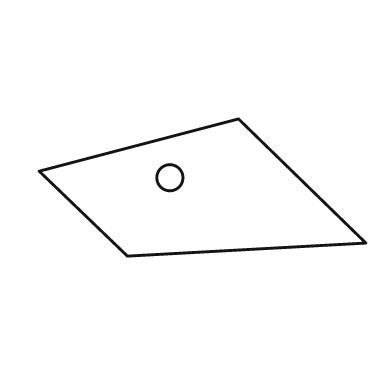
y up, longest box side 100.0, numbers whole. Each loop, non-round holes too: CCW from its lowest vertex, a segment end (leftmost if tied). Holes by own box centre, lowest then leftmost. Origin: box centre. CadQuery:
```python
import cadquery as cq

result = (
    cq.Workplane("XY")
    .moveTo(-23.0, -21.0)
    .lineTo(50.0, -17.0)
    .lineTo(11.0, 21.0)
    .lineTo(-50.0, 5.0)
    .close()
    .moveTo(-10.0, 3.0)
    .circle(4.0)
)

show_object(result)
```